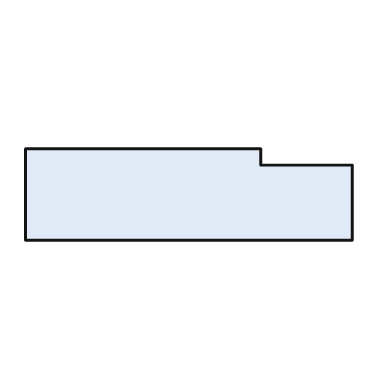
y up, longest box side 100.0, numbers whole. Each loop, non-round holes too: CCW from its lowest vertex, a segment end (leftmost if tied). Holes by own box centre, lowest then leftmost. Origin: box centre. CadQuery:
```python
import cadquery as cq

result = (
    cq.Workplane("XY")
    .moveTo(-50.0, -14.0)
    .lineTo(50.0, -14.0)
    .lineTo(50.0, 9.0)
    .lineTo(22.0, 9.0)
    .lineTo(22.0, 14.0)
    .lineTo(-50.0, 14.0)
    .close()
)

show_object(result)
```